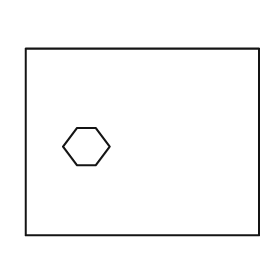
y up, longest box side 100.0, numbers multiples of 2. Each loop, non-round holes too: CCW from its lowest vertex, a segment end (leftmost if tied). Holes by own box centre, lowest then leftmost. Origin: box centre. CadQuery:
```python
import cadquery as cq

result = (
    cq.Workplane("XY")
    .moveTo(-50.0, -40.0)
    .lineTo(50.0, -40.0)
    .lineTo(50.0, 40.0)
    .lineTo(-50.0, 40.0)
    .close()
    .moveTo(-28.0, -10.0)
    .lineTo(-20.0, -10.0)
    .lineTo(-14.0, -2.0)
    .lineTo(-20.0, 6.0)
    .lineTo(-28.0, 6.0)
    .lineTo(-34.0, -2.0)
    .close()
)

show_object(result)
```